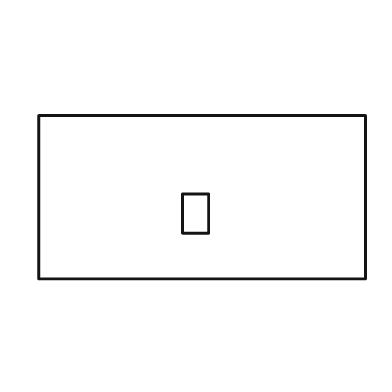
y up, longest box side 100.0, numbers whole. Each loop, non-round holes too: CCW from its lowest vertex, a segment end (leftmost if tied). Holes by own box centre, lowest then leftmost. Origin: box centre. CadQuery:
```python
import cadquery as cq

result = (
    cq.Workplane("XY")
    .moveTo(-50.0, -25.0)
    .lineTo(50.0, -25.0)
    .lineTo(50.0, 25.0)
    .lineTo(-50.0, 25.0)
    .close()
    .moveTo(-6.0, -11.0)
    .lineTo(2.0, -11.0)
    .lineTo(2.0, 1.0)
    .lineTo(-6.0, 1.0)
    .close()
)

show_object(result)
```